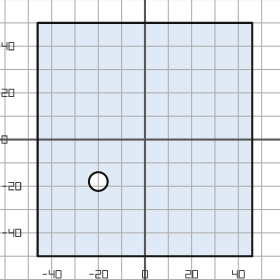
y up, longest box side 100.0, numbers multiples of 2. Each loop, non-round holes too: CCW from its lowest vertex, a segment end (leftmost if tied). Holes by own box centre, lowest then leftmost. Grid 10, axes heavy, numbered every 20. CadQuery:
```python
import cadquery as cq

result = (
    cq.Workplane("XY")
    .moveTo(-46.0, -50.0)
    .lineTo(46.0, -50.0)
    .lineTo(46.0, 50.0)
    .lineTo(-46.0, 50.0)
    .close()
    .moveTo(-20.0, -18.0)
    .circle(4.0)
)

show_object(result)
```